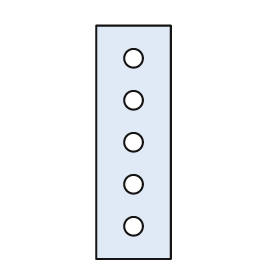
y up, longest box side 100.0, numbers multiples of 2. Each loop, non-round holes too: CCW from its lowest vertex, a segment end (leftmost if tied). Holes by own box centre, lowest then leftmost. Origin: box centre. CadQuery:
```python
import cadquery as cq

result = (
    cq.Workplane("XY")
    .moveTo(-16.0, -50.0)
    .lineTo(16.0, -50.0)
    .lineTo(16.0, 50.0)
    .lineTo(-16.0, 50.0)
    .close()
    .moveTo(0.0, -36.0)
    .circle(4.0)
    .moveTo(0.0, -18.0)
    .circle(4.0)
    .moveTo(0.0, 0.0)
    .circle(4.0)
    .moveTo(0.0, 18.0)
    .circle(4.0)
    .moveTo(0.0, 36.0)
    .circle(4.0)
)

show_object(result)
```